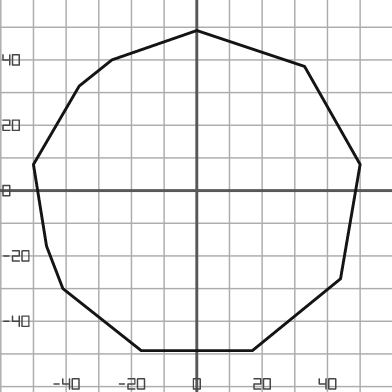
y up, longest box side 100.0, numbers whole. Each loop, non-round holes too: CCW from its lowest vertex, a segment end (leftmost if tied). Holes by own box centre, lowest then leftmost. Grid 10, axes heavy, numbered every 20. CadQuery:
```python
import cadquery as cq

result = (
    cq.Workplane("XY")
    .moveTo(-17.0, -49.0)
    .lineTo(17.0, -49.0)
    .lineTo(44.0, -27.0)
    .lineTo(50.0, 8.0)
    .lineTo(33.0, 38.0)
    .lineTo(0.0, 49.0)
    .lineTo(-26.0, 40.0)
    .lineTo(-36.0, 32.0)
    .lineTo(-50.0, 8.0)
    .lineTo(-46.0, -17.0)
    .lineTo(-41.0, -30.0)
    .close()
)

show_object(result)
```